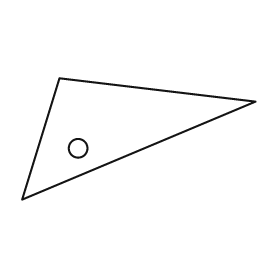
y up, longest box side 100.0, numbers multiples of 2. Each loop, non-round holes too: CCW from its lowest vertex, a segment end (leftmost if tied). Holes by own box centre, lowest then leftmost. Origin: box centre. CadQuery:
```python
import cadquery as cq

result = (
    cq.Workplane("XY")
    .moveTo(-50.0, -26.0)
    .lineTo(50.0, 16.0)
    .lineTo(-34.0, 26.0)
    .close()
    .moveTo(-26.0, -4.0)
    .circle(4.0)
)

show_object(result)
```